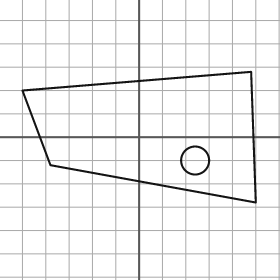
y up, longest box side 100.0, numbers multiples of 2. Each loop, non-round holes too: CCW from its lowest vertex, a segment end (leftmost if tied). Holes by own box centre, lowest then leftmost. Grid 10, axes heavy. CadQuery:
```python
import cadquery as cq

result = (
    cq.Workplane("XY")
    .moveTo(50.0, -28.0)
    .lineTo(48.0, 28.0)
    .lineTo(-50.0, 20.0)
    .lineTo(-38.0, -12.0)
    .close()
    .moveTo(24.0, -10.0)
    .circle(6.0)
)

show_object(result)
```